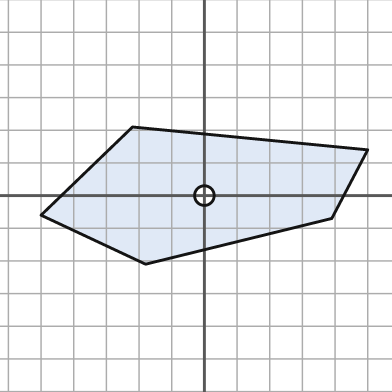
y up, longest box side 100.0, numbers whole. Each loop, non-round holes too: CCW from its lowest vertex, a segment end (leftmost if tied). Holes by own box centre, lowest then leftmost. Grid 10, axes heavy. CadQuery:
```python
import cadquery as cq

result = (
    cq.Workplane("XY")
    .moveTo(-18.0, -21.0)
    .lineTo(39.0, -7.0)
    .lineTo(50.0, 14.0)
    .lineTo(-22.0, 21.0)
    .lineTo(-50.0, -6.0)
    .close()
    .moveTo(0.0, 0.0)
    .circle(3.0)
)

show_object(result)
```